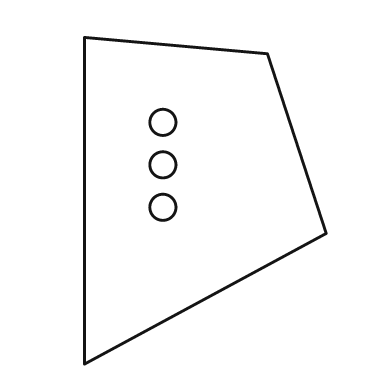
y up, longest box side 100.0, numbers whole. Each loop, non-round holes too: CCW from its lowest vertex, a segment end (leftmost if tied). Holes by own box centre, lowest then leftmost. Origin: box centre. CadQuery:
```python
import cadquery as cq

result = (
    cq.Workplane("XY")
    .moveTo(-37.0, -50.0)
    .lineTo(37.0, -10.0)
    .lineTo(19.0, 45.0)
    .lineTo(-37.0, 50.0)
    .close()
    .moveTo(-13.0, -2.0)
    .circle(4.0)
    .moveTo(-13.0, 11.0)
    .circle(4.0)
    .moveTo(-13.0, 24.0)
    .circle(4.0)
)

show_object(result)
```